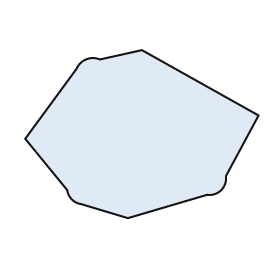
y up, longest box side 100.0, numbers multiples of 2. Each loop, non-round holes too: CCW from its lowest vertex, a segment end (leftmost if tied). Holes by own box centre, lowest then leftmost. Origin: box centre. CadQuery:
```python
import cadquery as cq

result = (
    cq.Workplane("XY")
    .moveTo(-6.0, -36.0)
    .lineTo(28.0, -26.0)
    .threePointArc((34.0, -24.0), (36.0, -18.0))
    .lineTo(50.0, 8.0)
    .lineTo(0.0, 36.0)
    .lineTo(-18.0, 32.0)
    .threePointArc((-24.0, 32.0), (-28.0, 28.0))
    .lineTo(-50.0, -2.0)
    .lineTo(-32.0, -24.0)
    .threePointArc((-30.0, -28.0), (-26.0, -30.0))
    .close()
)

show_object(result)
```